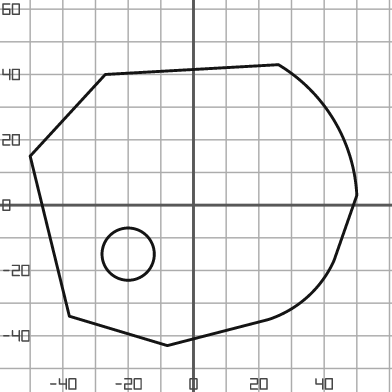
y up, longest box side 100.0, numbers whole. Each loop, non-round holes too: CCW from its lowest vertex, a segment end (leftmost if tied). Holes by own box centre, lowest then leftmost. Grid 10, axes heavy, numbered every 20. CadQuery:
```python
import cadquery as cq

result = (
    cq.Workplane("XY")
    .moveTo(-8.0, -43.0)
    .lineTo(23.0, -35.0)
    .threePointArc((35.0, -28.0), (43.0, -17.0))
    .lineTo(50.0, 3.0)
    .threePointArc((43.0, 26.0), (26.0, 43.0))
    .lineTo(-27.0, 40.0)
    .lineTo(-50.0, 15.0)
    .lineTo(-38.0, -34.0)
    .close()
    .moveTo(-20.0, -15.0)
    .circle(8.0)
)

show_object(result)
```